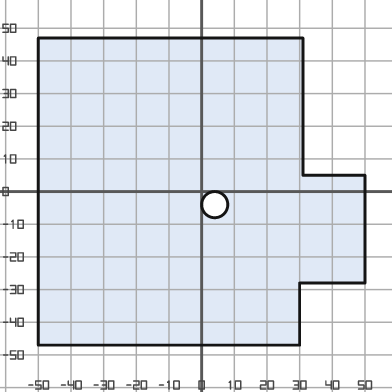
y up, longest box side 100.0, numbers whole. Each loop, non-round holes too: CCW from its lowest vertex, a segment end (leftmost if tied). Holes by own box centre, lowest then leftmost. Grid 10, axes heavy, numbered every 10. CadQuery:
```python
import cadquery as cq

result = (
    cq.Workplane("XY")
    .moveTo(-50.0, -47.0)
    .lineTo(30.0, -47.0)
    .lineTo(30.0, -28.0)
    .lineTo(50.0, -28.0)
    .lineTo(50.0, 5.0)
    .lineTo(31.0, 5.0)
    .lineTo(31.0, 47.0)
    .lineTo(-50.0, 47.0)
    .close()
    .moveTo(4.0, -4.0)
    .circle(4.0)
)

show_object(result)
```